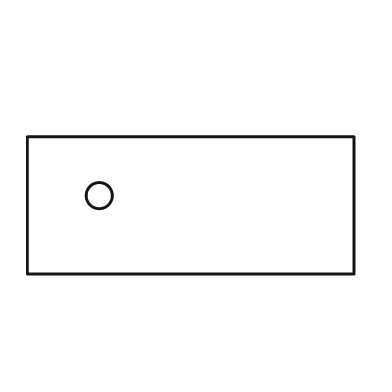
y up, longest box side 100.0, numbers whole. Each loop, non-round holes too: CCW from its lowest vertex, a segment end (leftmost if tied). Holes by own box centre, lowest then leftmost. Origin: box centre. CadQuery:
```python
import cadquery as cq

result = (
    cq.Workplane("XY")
    .moveTo(-50.0, -21.0)
    .lineTo(50.0, -21.0)
    .lineTo(50.0, 21.0)
    .lineTo(-50.0, 21.0)
    .close()
    .moveTo(-28.0, 3.0)
    .circle(4.0)
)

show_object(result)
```